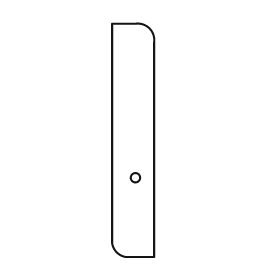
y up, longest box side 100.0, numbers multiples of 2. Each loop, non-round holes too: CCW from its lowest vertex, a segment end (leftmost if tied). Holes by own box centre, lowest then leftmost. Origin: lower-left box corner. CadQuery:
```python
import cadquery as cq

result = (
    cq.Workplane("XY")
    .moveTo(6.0, 0.0)
    .lineTo(18.0, 0.0)
    .lineTo(18.0, 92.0)
    .threePointArc((16.0, 98.0), (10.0, 100.0))
    .lineTo(0.0, 100.0)
    .lineTo(0.0, 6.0)
    .threePointArc((2.0, 2.0), (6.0, 0.0))
    .close()
    .moveTo(10.0, 34.0)
    .circle(2.0)
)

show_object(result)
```